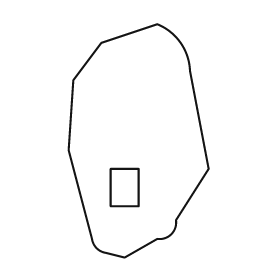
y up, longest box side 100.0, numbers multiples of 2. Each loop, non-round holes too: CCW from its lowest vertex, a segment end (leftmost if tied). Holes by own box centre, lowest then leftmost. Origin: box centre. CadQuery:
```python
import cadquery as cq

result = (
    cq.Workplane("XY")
    .moveTo(-6.0, -50.0)
    .lineTo(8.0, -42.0)
    .threePointArc((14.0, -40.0), (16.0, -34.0))
    .lineTo(30.0, -12.0)
    .lineTo(22.0, 30.0)
    .threePointArc((18.0, 42.0), (8.0, 50.0))
    .lineTo(-16.0, 42.0)
    .lineTo(-28.0, 26.0)
    .lineTo(-30.0, -4.0)
    .lineTo(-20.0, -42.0)
    .threePointArc((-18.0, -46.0), (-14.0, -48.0))
    .close()
    .moveTo(-12.0, -28.0)
    .lineTo(0.0, -28.0)
    .lineTo(0.0, -12.0)
    .lineTo(-12.0, -12.0)
    .close()
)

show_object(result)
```